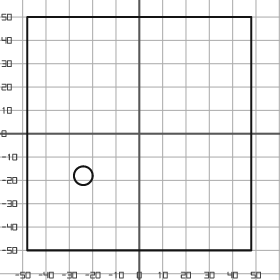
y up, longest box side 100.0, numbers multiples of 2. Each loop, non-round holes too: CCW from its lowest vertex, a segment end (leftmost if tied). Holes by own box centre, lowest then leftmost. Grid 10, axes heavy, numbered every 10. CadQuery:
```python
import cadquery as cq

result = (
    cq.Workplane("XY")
    .moveTo(-48.0, -50.0)
    .lineTo(48.0, -50.0)
    .lineTo(48.0, 50.0)
    .lineTo(-48.0, 50.0)
    .close()
    .moveTo(-24.0, -18.0)
    .circle(4.0)
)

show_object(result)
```